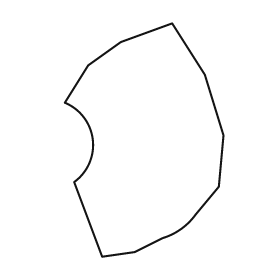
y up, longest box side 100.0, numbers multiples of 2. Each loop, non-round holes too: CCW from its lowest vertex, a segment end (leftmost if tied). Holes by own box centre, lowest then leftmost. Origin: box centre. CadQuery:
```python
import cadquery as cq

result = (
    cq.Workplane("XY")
    .moveTo(-18.0, -50.0)
    .lineTo(-4.0, -48.0)
    .lineTo(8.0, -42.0)
    .threePointArc((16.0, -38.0), (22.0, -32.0))
    .lineTo(32.0, -20.0)
    .lineTo(34.0, 2.0)
    .lineTo(26.0, 28.0)
    .lineTo(12.0, 50.0)
    .lineTo(-10.0, 42.0)
    .lineTo(-24.0, 32.0)
    .lineTo(-34.0, 16.0)
    .threePointArc((-22.0, 0.0), (-30.0, -18.0))
    .close()
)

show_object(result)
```